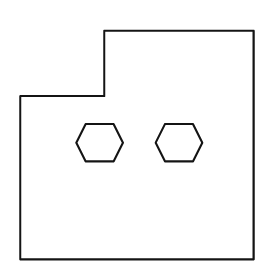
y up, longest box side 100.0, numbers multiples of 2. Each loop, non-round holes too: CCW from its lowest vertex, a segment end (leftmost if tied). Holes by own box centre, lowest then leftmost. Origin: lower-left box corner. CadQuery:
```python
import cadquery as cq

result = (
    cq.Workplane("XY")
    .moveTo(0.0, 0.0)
    .lineTo(100.0, 0.0)
    .lineTo(100.0, 98.0)
    .lineTo(36.0, 98.0)
    .lineTo(36.0, 70.0)
    .lineTo(0.0, 70.0)
    .close()
    .moveTo(28.0, 42.0)
    .lineTo(40.0, 42.0)
    .lineTo(44.0, 50.0)
    .lineTo(40.0, 58.0)
    .lineTo(28.0, 58.0)
    .lineTo(24.0, 50.0)
    .close()
    .moveTo(62.0, 42.0)
    .lineTo(74.0, 42.0)
    .lineTo(78.0, 50.0)
    .lineTo(74.0, 58.0)
    .lineTo(62.0, 58.0)
    .lineTo(58.0, 50.0)
    .close()
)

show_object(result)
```